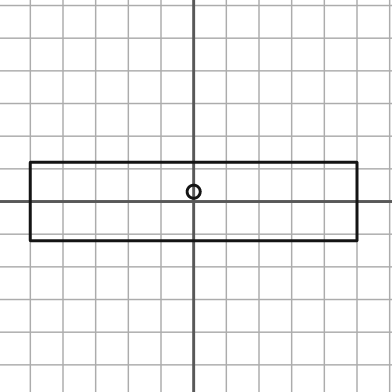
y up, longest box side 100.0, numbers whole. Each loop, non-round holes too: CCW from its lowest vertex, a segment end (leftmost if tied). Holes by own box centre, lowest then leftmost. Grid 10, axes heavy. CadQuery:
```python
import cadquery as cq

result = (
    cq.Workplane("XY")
    .moveTo(-50.0, -12.0)
    .lineTo(50.0, -12.0)
    .lineTo(50.0, 12.0)
    .lineTo(-50.0, 12.0)
    .close()
    .moveTo(0.0, 3.0)
    .circle(2.0)
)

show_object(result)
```